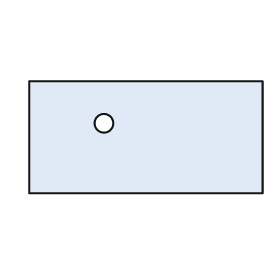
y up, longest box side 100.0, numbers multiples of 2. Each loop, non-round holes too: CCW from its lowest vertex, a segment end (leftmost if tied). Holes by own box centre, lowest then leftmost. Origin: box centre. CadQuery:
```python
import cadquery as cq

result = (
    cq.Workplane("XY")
    .moveTo(-50.0, -24.0)
    .lineTo(50.0, -24.0)
    .lineTo(50.0, 24.0)
    .lineTo(-50.0, 24.0)
    .close()
    .moveTo(-18.0, 6.0)
    .circle(4.0)
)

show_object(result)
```